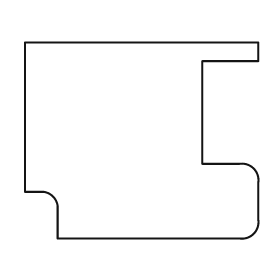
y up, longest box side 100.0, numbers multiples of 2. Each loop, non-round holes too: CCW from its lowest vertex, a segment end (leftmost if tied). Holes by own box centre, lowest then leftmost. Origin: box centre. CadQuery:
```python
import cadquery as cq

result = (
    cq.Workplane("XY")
    .moveTo(-36.0, -42.0)
    .lineTo(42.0, -42.0)
    .threePointArc((48.0, -40.0), (50.0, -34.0))
    .lineTo(50.0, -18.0)
    .threePointArc((48.0, -12.0), (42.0, -10.0))
    .lineTo(26.0, -10.0)
    .lineTo(26.0, 34.0)
    .lineTo(50.0, 34.0)
    .lineTo(50.0, 42.0)
    .lineTo(-50.0, 42.0)
    .lineTo(-50.0, -22.0)
    .lineTo(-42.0, -22.0)
    .threePointArc((-38.0, -24.0), (-36.0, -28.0))
    .close()
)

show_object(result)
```